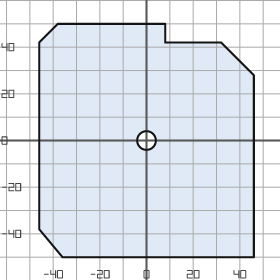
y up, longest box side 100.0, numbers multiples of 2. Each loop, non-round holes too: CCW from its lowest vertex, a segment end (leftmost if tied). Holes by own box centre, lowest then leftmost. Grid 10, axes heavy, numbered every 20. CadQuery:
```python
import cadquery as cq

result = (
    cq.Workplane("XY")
    .moveTo(-36.0, -50.0)
    .lineTo(46.0, -50.0)
    .lineTo(46.0, 28.0)
    .lineTo(32.0, 42.0)
    .lineTo(8.0, 42.0)
    .lineTo(8.0, 50.0)
    .lineTo(-38.0, 50.0)
    .lineTo(-46.0, 42.0)
    .lineTo(-46.0, -38.0)
    .close()
    .moveTo(0.0, 0.0)
    .circle(4.0)
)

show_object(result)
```